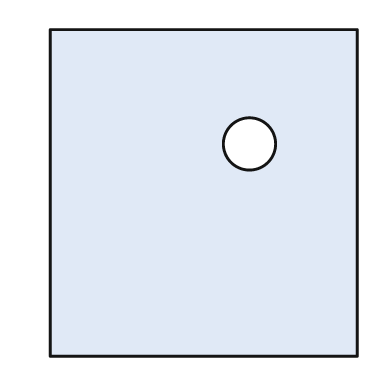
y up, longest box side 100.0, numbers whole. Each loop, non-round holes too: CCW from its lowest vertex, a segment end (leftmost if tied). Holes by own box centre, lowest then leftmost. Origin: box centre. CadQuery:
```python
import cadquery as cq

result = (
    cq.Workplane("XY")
    .moveTo(-47.0, -50.0)
    .lineTo(47.0, -50.0)
    .lineTo(47.0, 50.0)
    .lineTo(-47.0, 50.0)
    .close()
    .moveTo(14.0, 15.0)
    .circle(8.0)
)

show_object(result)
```